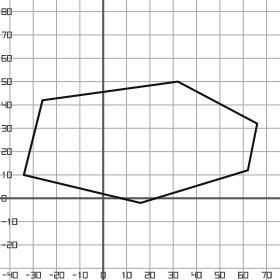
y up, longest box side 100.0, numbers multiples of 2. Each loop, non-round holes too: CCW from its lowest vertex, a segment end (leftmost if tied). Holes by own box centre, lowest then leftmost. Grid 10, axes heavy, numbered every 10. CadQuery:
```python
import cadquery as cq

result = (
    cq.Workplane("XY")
    .moveTo(16.0, -2.0)
    .lineTo(62.0, 12.0)
    .lineTo(66.0, 32.0)
    .lineTo(32.0, 50.0)
    .lineTo(-26.0, 42.0)
    .lineTo(-34.0, 10.0)
    .close()
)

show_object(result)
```